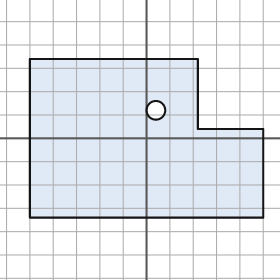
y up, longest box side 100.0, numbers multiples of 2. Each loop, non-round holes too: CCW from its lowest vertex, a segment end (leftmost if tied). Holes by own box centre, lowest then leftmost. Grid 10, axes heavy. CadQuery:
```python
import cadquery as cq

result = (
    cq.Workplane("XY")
    .moveTo(-50.0, -34.0)
    .lineTo(50.0, -34.0)
    .lineTo(50.0, 4.0)
    .lineTo(22.0, 4.0)
    .lineTo(22.0, 34.0)
    .lineTo(-50.0, 34.0)
    .close()
    .moveTo(4.0, 12.0)
    .circle(4.0)
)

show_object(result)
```